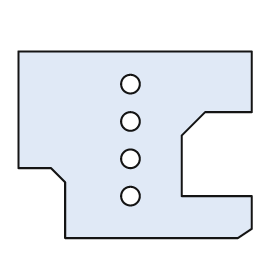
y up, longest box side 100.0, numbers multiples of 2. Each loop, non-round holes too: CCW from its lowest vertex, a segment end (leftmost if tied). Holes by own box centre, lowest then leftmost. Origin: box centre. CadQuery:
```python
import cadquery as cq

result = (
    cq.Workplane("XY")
    .moveTo(-30.0, -40.0)
    .lineTo(44.0, -40.0)
    .lineTo(50.0, -36.0)
    .lineTo(50.0, -22.0)
    .lineTo(20.0, -22.0)
    .lineTo(20.0, 4.0)
    .lineTo(30.0, 14.0)
    .lineTo(50.0, 14.0)
    .lineTo(50.0, 40.0)
    .lineTo(-50.0, 40.0)
    .lineTo(-50.0, -10.0)
    .lineTo(-36.0, -10.0)
    .lineTo(-30.0, -16.0)
    .close()
    .moveTo(-2.0, -22.0)
    .circle(4.0)
    .moveTo(-2.0, -6.0)
    .circle(4.0)
    .moveTo(-2.0, 10.0)
    .circle(4.0)
    .moveTo(-2.0, 26.0)
    .circle(4.0)
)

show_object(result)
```